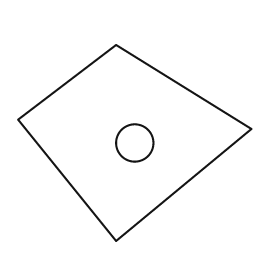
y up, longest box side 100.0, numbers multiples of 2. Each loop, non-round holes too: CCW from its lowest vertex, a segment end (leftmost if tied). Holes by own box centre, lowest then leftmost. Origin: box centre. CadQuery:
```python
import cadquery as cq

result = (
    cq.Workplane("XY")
    .moveTo(-8.0, -42.0)
    .lineTo(50.0, 6.0)
    .lineTo(-8.0, 42.0)
    .lineTo(-50.0, 10.0)
    .close()
    .moveTo(0.0, 0.0)
    .circle(8.0)
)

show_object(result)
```